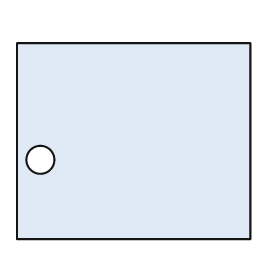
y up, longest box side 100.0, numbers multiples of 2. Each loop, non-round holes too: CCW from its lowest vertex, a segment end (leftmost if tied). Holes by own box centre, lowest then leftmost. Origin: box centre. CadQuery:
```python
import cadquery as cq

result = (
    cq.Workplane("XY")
    .moveTo(-50.0, -42.0)
    .lineTo(50.0, -42.0)
    .lineTo(50.0, 42.0)
    .lineTo(-50.0, 42.0)
    .close()
    .moveTo(-40.0, -8.0)
    .circle(6.0)
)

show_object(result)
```